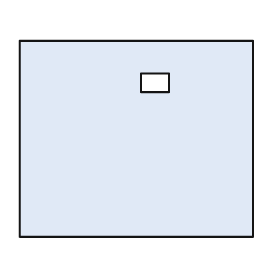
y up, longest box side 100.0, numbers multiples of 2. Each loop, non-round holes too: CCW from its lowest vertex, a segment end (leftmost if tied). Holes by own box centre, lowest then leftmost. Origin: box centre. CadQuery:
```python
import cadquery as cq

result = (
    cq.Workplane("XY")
    .moveTo(-50.0, -42.0)
    .lineTo(50.0, -42.0)
    .lineTo(50.0, 42.0)
    .lineTo(-50.0, 42.0)
    .close()
    .moveTo(2.0, 20.0)
    .lineTo(14.0, 20.0)
    .lineTo(14.0, 28.0)
    .lineTo(2.0, 28.0)
    .close()
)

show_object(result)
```